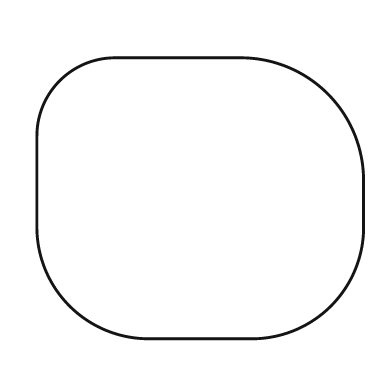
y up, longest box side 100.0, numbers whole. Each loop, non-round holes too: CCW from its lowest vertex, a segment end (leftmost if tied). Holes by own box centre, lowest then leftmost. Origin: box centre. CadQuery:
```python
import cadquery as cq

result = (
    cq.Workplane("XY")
    .moveTo(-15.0, -43.0)
    .lineTo(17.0, -43.0)
    .threePointArc((40.0, -33.0), (50.0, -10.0))
    .lineTo(50.0, 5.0)
    .threePointArc((39.0, 32.0), (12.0, 43.0))
    .lineTo(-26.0, 43.0)
    .threePointArc((-43.0, 36.0), (-50.0, 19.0))
    .lineTo(-50.0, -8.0)
    .threePointArc((-40.0, -33.0), (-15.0, -43.0))
    .close()
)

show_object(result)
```